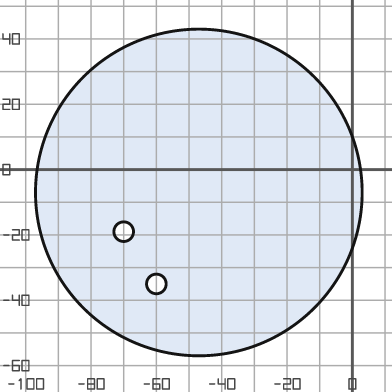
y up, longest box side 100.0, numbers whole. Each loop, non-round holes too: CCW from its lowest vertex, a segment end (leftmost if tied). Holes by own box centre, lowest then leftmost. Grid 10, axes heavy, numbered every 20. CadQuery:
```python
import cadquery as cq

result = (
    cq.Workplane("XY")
    .moveTo(-47.0, -7.0)
    .circle(50.0)
    .moveTo(-60.0, -35.0)
    .circle(3.0)
    .moveTo(-70.0, -19.0)
    .circle(3.0)
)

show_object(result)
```